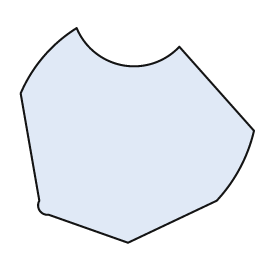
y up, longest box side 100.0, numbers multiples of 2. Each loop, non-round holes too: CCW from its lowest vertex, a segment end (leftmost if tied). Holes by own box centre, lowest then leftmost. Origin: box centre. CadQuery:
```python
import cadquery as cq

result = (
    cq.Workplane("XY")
    .moveTo(-4.0, -46.0)
    .lineTo(34.0, -28.0)
    .threePointArc((44.0, -14.0), (50.0, 2.0))
    .lineTo(18.0, 38.0)
    .threePointArc((-6.0, 30.0), (-26.0, 46.0))
    .threePointArc((-40.0, 34.0), (-50.0, 18.0))
    .lineTo(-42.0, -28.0)
    .threePointArc((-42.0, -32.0), (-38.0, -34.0))
    .close()
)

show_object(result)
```